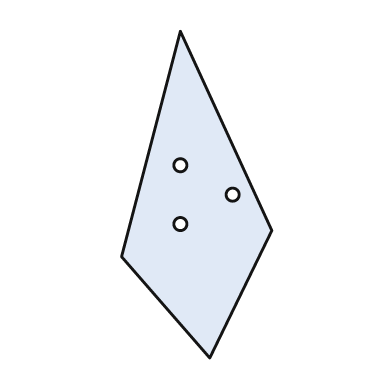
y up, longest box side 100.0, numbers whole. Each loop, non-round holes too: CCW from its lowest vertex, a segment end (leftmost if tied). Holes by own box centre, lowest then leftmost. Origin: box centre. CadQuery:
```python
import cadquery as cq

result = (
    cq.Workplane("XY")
    .moveTo(4.0, -50.0)
    .lineTo(23.0, -11.0)
    .lineTo(-5.0, 50.0)
    .lineTo(-23.0, -19.0)
    .close()
    .moveTo(-5.0, -9.0)
    .circle(2.0)
    .moveTo(11.0, 0.0)
    .circle(2.0)
    .moveTo(-5.0, 9.0)
    .circle(2.0)
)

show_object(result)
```